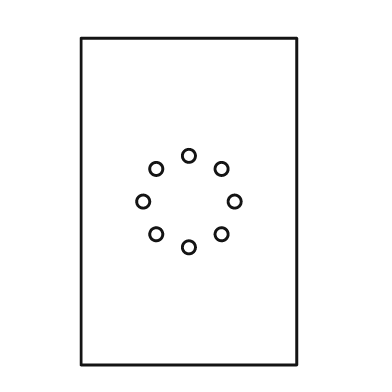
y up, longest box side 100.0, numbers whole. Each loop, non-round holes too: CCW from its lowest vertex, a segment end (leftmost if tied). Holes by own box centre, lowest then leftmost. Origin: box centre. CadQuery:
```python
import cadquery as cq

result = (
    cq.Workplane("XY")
    .moveTo(-33.0, -50.0)
    .lineTo(33.0, -50.0)
    .lineTo(33.0, 50.0)
    .lineTo(-33.0, 50.0)
    .close()
    .moveTo(0.0, -14.0)
    .circle(2.0)
    .moveTo(-10.0, -10.0)
    .circle(2.0)
    .moveTo(10.0, -10.0)
    .circle(2.0)
    .moveTo(-14.0, 0.0)
    .circle(2.0)
    .moveTo(14.0, 0.0)
    .circle(2.0)
    .moveTo(-10.0, 10.0)
    .circle(2.0)
    .moveTo(10.0, 10.0)
    .circle(2.0)
    .moveTo(0.0, 14.0)
    .circle(2.0)
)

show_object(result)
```